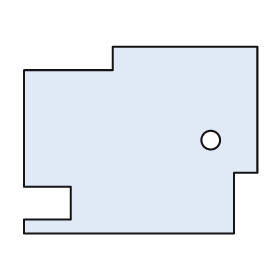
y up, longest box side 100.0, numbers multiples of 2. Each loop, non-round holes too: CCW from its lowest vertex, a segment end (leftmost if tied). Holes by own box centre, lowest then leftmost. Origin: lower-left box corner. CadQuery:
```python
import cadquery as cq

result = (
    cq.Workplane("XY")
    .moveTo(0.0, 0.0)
    .lineTo(90.0, 0.0)
    .lineTo(90.0, 26.0)
    .lineTo(100.0, 26.0)
    .lineTo(100.0, 80.0)
    .lineTo(38.0, 80.0)
    .lineTo(38.0, 70.0)
    .lineTo(0.0, 70.0)
    .lineTo(0.0, 20.0)
    .lineTo(20.0, 20.0)
    .lineTo(20.0, 6.0)
    .lineTo(0.0, 6.0)
    .close()
    .moveTo(80.0, 40.0)
    .circle(4.0)
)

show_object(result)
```